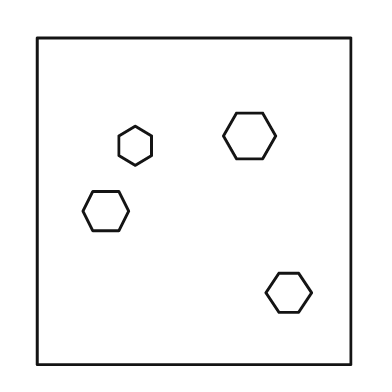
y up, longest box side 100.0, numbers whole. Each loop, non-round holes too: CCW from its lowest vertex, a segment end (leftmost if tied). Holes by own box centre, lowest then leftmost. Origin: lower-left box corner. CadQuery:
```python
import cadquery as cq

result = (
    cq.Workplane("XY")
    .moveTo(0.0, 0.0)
    .lineTo(96.0, 0.0)
    .lineTo(96.0, 100.0)
    .lineTo(0.0, 100.0)
    .close()
    .moveTo(74.0, 16.0)
    .lineTo(80.0, 16.0)
    .lineTo(84.0, 22.0)
    .lineTo(80.0, 28.0)
    .lineTo(74.0, 28.0)
    .lineTo(70.0, 22.0)
    .close()
    .moveTo(17.0, 41.0)
    .lineTo(25.0, 41.0)
    .lineTo(28.0, 47.0)
    .lineTo(25.0, 53.0)
    .lineTo(17.0, 53.0)
    .lineTo(14.0, 47.0)
    .close()
    .moveTo(30.0, 61.0)
    .lineTo(35.0, 64.0)
    .lineTo(35.0, 70.0)
    .lineTo(30.0, 73.0)
    .lineTo(25.0, 70.0)
    .lineTo(25.0, 64.0)
    .close()
    .moveTo(61.0, 63.0)
    .lineTo(69.0, 63.0)
    .lineTo(73.0, 70.0)
    .lineTo(69.0, 77.0)
    .lineTo(61.0, 77.0)
    .lineTo(57.0, 70.0)
    .close()
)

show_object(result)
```